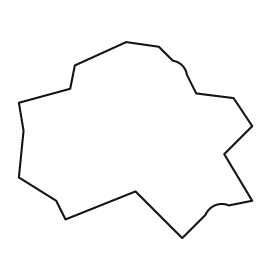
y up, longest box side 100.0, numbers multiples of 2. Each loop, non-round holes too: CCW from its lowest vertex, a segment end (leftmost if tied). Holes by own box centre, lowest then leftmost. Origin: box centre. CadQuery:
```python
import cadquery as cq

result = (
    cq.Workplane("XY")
    .moveTo(20.0, -42.0)
    .lineTo(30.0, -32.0)
    .threePointArc((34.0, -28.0), (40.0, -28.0))
    .lineTo(50.0, -26.0)
    .lineTo(38.0, -6.0)
    .lineTo(50.0, 6.0)
    .lineTo(42.0, 18.0)
    .lineTo(26.0, 20.0)
    .lineTo(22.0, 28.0)
    .threePointArc((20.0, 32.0), (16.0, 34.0))
    .lineTo(10.0, 40.0)
    .lineTo(-4.0, 42.0)
    .lineTo(-26.0, 32.0)
    .lineTo(-28.0, 22.0)
    .lineTo(-50.0, 16.0)
    .lineTo(-48.0, 4.0)
    .lineTo(-50.0, -16.0)
    .lineTo(-34.0, -26.0)
    .lineTo(-30.0, -34.0)
    .lineTo(0.0, -22.0)
    .close()
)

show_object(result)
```